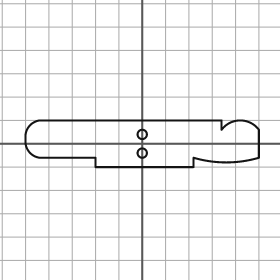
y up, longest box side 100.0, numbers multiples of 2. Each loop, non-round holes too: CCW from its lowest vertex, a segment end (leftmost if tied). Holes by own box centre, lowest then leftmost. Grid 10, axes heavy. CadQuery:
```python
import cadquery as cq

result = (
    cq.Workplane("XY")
    .moveTo(-20.0, -10.0)
    .lineTo(22.0, -10.0)
    .lineTo(22.0, -6.0)
    .threePointArc((36.0, -8.0), (50.0, -6.0))
    .lineTo(50.0, 6.0)
    .threePointArc((42.0, 10.0), (34.0, 6.0))
    .lineTo(34.0, 10.0)
    .lineTo(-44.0, 10.0)
    .threePointArc((-48.0, 8.0), (-50.0, 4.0))
    .lineTo(-50.0, 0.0)
    .threePointArc((-48.0, -4.0), (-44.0, -6.0))
    .lineTo(-20.0, -6.0)
    .close()
    .moveTo(0.0, -4.0)
    .circle(2.0)
    .moveTo(0.0, 4.0)
    .circle(2.0)
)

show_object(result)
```